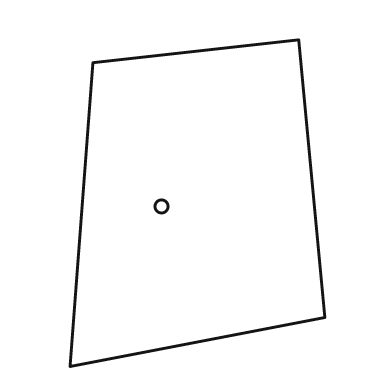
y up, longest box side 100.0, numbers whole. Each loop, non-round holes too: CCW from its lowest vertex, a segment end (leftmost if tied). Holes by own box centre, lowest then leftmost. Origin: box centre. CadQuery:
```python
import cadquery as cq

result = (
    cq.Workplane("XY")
    .moveTo(-39.0, -50.0)
    .lineTo(39.0, -35.0)
    .lineTo(31.0, 50.0)
    .lineTo(-32.0, 43.0)
    .close()
    .moveTo(-11.0, -1.0)
    .circle(2.0)
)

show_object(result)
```